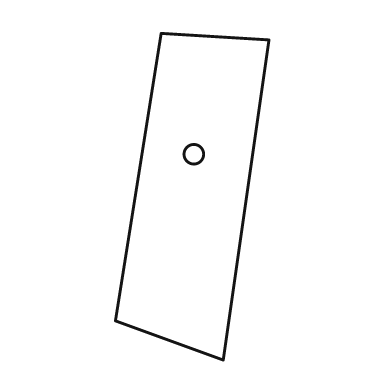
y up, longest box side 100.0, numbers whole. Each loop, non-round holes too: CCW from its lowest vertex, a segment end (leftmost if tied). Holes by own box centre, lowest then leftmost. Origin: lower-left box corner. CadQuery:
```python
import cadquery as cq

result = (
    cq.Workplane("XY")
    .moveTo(33.0, 0.0)
    .lineTo(47.0, 98.0)
    .lineTo(14.0, 100.0)
    .lineTo(0.0, 12.0)
    .close()
    .moveTo(24.0, 63.0)
    .circle(3.0)
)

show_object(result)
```